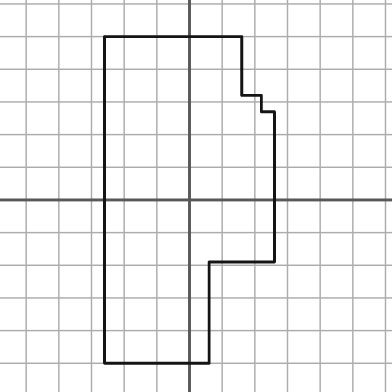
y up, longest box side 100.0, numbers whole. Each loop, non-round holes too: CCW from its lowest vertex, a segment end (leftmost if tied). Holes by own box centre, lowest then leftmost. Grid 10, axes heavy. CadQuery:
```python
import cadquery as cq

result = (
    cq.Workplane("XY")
    .moveTo(-26.0, -50.0)
    .lineTo(6.0, -50.0)
    .lineTo(6.0, -19.0)
    .lineTo(26.0, -19.0)
    .lineTo(26.0, 27.0)
    .lineTo(22.0, 27.0)
    .lineTo(22.0, 32.0)
    .lineTo(16.0, 32.0)
    .lineTo(16.0, 50.0)
    .lineTo(-26.0, 50.0)
    .close()
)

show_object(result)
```